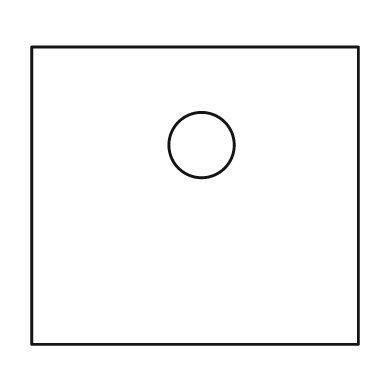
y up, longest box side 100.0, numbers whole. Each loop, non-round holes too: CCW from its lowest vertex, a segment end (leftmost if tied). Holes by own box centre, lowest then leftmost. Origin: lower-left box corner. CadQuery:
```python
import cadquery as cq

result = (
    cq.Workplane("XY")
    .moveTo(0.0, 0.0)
    .lineTo(100.0, 0.0)
    .lineTo(100.0, 91.0)
    .lineTo(0.0, 91.0)
    .close()
    .moveTo(52.0, 61.0)
    .circle(10.0)
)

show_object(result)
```